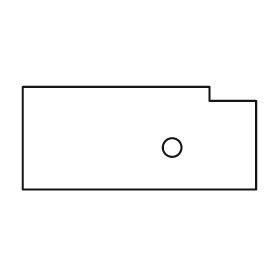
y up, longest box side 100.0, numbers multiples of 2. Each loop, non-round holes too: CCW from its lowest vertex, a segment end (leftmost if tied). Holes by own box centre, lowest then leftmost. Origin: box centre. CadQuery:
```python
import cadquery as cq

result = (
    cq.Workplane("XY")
    .moveTo(-50.0, -22.0)
    .lineTo(50.0, -22.0)
    .lineTo(50.0, 16.0)
    .lineTo(30.0, 16.0)
    .lineTo(30.0, 22.0)
    .lineTo(-50.0, 22.0)
    .close()
    .moveTo(14.0, -4.0)
    .circle(4.0)
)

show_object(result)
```